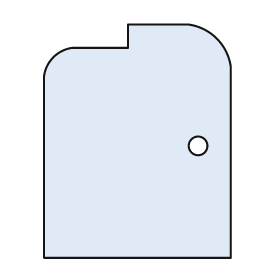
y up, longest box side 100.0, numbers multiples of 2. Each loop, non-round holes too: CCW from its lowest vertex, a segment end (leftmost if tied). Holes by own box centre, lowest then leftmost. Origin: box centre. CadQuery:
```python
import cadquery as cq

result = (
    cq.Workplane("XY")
    .moveTo(-40.0, -50.0)
    .lineTo(40.0, -50.0)
    .lineTo(40.0, 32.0)
    .threePointArc((34.0, 44.0), (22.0, 50.0))
    .lineTo(-4.0, 50.0)
    .lineTo(-4.0, 40.0)
    .lineTo(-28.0, 40.0)
    .threePointArc((-36.0, 36.0), (-40.0, 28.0))
    .close()
    .moveTo(26.0, -2.0)
    .circle(4.0)
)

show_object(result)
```